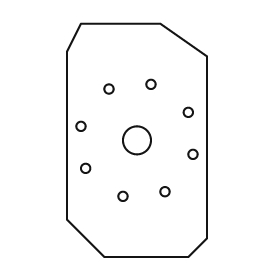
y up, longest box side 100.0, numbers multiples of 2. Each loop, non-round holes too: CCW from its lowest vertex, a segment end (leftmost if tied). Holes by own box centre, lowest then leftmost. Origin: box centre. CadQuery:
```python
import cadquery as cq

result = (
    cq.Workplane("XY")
    .moveTo(-14.0, -50.0)
    .lineTo(22.0, -50.0)
    .lineTo(30.0, -42.0)
    .lineTo(30.0, 36.0)
    .lineTo(10.0, 50.0)
    .lineTo(-24.0, 50.0)
    .lineTo(-30.0, 38.0)
    .lineTo(-30.0, -34.0)
    .close()
    .moveTo(-6.0, -24.0)
    .circle(2.0)
    .moveTo(12.0, -22.0)
    .circle(2.0)
    .moveTo(-22.0, -12.0)
    .circle(2.0)
    .moveTo(24.0, -6.0)
    .circle(2.0)
    .moveTo(0.0, 0.0)
    .circle(6.0)
    .moveTo(-24.0, 6.0)
    .circle(2.0)
    .moveTo(22.0, 12.0)
    .circle(2.0)
    .moveTo(-12.0, 22.0)
    .circle(2.0)
    .moveTo(6.0, 24.0)
    .circle(2.0)
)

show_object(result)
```